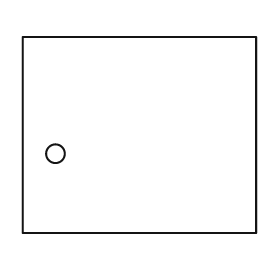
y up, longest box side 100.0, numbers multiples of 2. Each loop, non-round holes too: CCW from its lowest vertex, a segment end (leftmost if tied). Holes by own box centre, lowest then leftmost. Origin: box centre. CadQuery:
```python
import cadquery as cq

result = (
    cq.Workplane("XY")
    .moveTo(-50.0, -42.0)
    .lineTo(50.0, -42.0)
    .lineTo(50.0, 42.0)
    .lineTo(-50.0, 42.0)
    .close()
    .moveTo(-36.0, -8.0)
    .circle(4.0)
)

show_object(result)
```